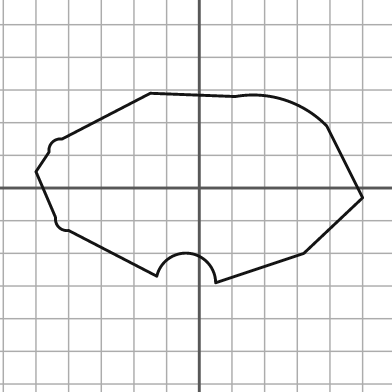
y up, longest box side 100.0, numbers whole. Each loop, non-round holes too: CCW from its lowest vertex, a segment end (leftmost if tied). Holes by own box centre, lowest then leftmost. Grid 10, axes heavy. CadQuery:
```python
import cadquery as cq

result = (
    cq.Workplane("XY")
    .moveTo(5.0, -29.0)
    .lineTo(32.0, -20.0)
    .lineTo(50.0, -3.0)
    .lineTo(39.0, 19.0)
    .threePointArc((26.0, 27.0), (11.0, 28.0))
    .lineTo(-15.0, 29.0)
    .lineTo(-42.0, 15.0)
    .threePointArc((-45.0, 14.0), (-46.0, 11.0))
    .lineTo(-50.0, 5.0)
    .lineTo(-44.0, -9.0)
    .threePointArc((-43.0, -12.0), (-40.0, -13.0))
    .lineTo(-13.0, -27.0)
    .threePointArc((-3.0, -20.0), (5.0, -29.0))
    .close()
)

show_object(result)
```